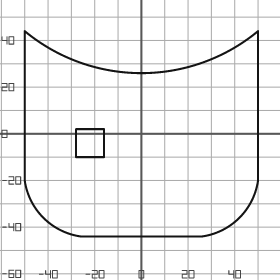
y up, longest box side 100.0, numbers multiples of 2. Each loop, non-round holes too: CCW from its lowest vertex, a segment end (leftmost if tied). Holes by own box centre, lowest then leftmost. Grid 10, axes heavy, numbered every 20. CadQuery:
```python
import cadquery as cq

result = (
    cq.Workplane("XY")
    .moveTo(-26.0, -44.0)
    .lineTo(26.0, -44.0)
    .threePointArc((42.0, -36.0), (50.0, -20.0))
    .lineTo(50.0, 44.0)
    .threePointArc((0.0, 26.0), (-50.0, 44.0))
    .lineTo(-50.0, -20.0)
    .threePointArc((-42.0, -36.0), (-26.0, -44.0))
    .close()
    .moveTo(-28.0, -10.0)
    .lineTo(-16.0, -10.0)
    .lineTo(-16.0, 2.0)
    .lineTo(-28.0, 2.0)
    .close()
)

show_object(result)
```